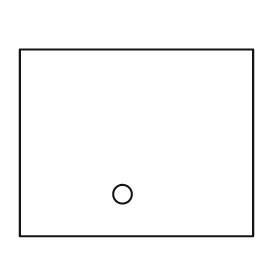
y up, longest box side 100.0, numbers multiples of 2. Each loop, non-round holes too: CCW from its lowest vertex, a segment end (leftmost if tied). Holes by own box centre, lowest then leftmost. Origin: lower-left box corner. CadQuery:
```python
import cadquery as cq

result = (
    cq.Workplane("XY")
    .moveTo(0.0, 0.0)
    .lineTo(100.0, 0.0)
    .lineTo(100.0, 80.0)
    .lineTo(0.0, 80.0)
    .close()
    .moveTo(44.0, 18.0)
    .circle(4.0)
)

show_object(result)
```